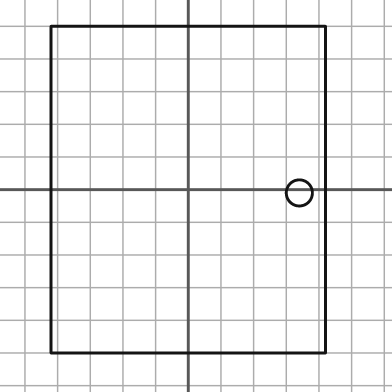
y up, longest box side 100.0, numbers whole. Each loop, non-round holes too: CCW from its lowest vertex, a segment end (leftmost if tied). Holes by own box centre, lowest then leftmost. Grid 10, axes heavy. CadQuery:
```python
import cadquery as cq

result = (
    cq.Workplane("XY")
    .moveTo(-42.0, -50.0)
    .lineTo(42.0, -50.0)
    .lineTo(42.0, 50.0)
    .lineTo(-42.0, 50.0)
    .close()
    .moveTo(34.0, -1.0)
    .circle(4.0)
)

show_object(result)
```